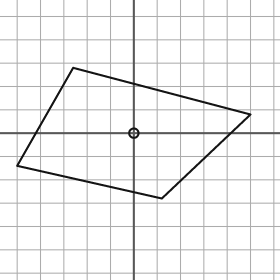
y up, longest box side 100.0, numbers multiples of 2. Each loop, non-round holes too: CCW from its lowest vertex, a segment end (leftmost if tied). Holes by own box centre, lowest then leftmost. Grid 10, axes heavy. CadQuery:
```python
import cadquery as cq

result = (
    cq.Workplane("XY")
    .moveTo(12.0, -28.0)
    .lineTo(50.0, 8.0)
    .lineTo(-26.0, 28.0)
    .lineTo(-50.0, -14.0)
    .close()
    .moveTo(0.0, 0.0)
    .circle(2.0)
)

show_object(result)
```